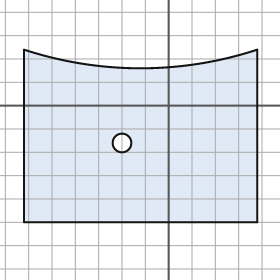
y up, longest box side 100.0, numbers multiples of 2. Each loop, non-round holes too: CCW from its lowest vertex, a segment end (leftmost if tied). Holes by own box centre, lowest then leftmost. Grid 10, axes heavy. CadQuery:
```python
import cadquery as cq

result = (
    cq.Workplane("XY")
    .moveTo(-62.0, -50.0)
    .lineTo(38.0, -50.0)
    .lineTo(38.0, 24.0)
    .threePointArc((-12.0, 16.0), (-62.0, 24.0))
    .close()
    .moveTo(-20.0, -16.0)
    .circle(4.0)
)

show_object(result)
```